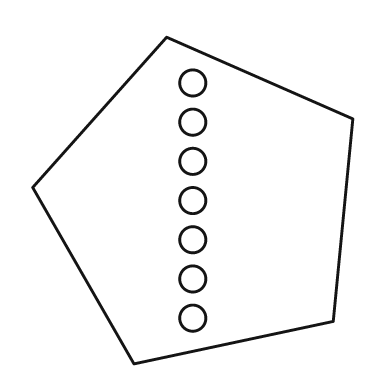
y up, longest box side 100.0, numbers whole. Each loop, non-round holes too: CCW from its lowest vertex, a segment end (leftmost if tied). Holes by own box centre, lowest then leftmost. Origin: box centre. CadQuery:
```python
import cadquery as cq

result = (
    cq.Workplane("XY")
    .moveTo(-18.0, -50.0)
    .lineTo(43.0, -37.0)
    .lineTo(49.0, 25.0)
    .lineTo(-8.0, 50.0)
    .lineTo(-49.0, 4.0)
    .close()
    .moveTo(0.0, -36.0)
    .circle(4.0)
    .moveTo(0.0, -24.0)
    .circle(4.0)
    .moveTo(0.0, -12.0)
    .circle(4.0)
    .moveTo(0.0, 0.0)
    .circle(4.0)
    .moveTo(0.0, 12.0)
    .circle(4.0)
    .moveTo(0.0, 24.0)
    .circle(4.0)
    .moveTo(0.0, 36.0)
    .circle(4.0)
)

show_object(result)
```